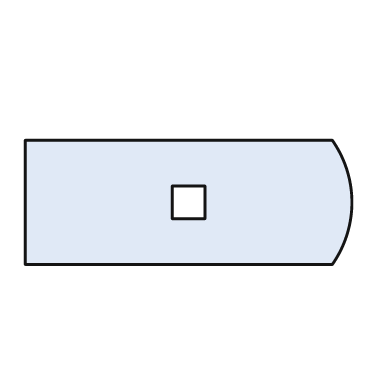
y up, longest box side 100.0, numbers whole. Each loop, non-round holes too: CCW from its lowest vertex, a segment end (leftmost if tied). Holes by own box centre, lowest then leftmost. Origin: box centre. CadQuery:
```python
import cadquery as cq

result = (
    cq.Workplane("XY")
    .moveTo(-50.0, -19.0)
    .lineTo(44.0, -19.0)
    .threePointArc((50.0, 0.0), (44.0, 19.0))
    .lineTo(-50.0, 19.0)
    .close()
    .moveTo(-5.0, -5.0)
    .lineTo(5.0, -5.0)
    .lineTo(5.0, 5.0)
    .lineTo(-5.0, 5.0)
    .close()
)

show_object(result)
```